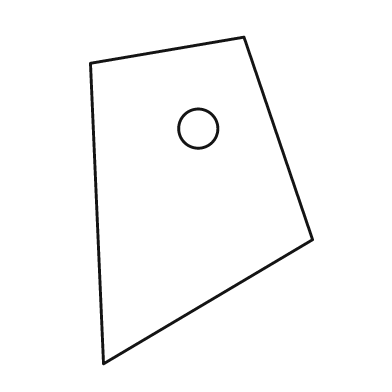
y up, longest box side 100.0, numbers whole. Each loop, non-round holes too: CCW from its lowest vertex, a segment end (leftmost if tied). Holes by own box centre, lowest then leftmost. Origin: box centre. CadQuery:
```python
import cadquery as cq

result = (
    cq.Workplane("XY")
    .moveTo(-30.0, -50.0)
    .lineTo(34.0, -12.0)
    .lineTo(13.0, 50.0)
    .lineTo(-34.0, 42.0)
    .close()
    .moveTo(-1.0, 22.0)
    .circle(6.0)
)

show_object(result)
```